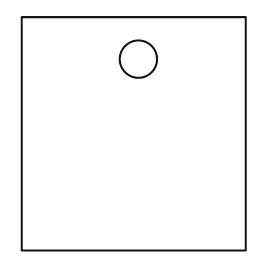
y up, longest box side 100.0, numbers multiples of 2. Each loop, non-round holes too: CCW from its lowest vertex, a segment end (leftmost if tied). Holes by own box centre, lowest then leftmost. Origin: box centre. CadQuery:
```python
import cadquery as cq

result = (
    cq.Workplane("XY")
    .moveTo(-48.0, -50.0)
    .lineTo(48.0, -50.0)
    .lineTo(48.0, 50.0)
    .lineTo(-48.0, 50.0)
    .close()
    .moveTo(2.0, 32.0)
    .circle(8.0)
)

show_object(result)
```